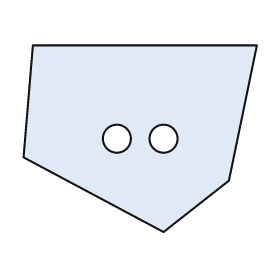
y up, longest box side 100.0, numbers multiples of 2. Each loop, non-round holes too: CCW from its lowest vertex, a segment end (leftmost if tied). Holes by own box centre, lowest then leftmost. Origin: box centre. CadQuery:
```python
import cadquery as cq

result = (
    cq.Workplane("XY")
    .moveTo(10.0, -40.0)
    .lineTo(38.0, -18.0)
    .lineTo(50.0, 40.0)
    .lineTo(-46.0, 40.0)
    .lineTo(-50.0, -8.0)
    .close()
    .moveTo(-10.0, 0.0)
    .circle(6.0)
    .moveTo(10.0, 0.0)
    .circle(6.0)
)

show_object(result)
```